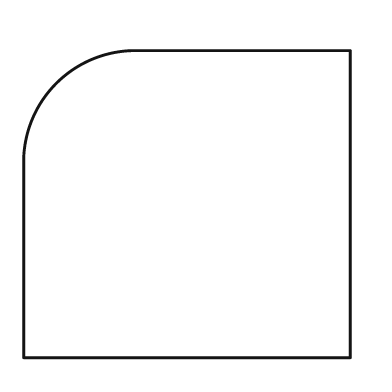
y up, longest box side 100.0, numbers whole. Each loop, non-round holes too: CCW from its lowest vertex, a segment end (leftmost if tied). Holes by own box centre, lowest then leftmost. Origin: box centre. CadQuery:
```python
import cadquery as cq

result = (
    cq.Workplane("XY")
    .moveTo(-50.0, -47.0)
    .lineTo(50.0, -47.0)
    .lineTo(50.0, 47.0)
    .lineTo(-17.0, 47.0)
    .threePointArc((-40.0, 37.0), (-50.0, 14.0))
    .close()
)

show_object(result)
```